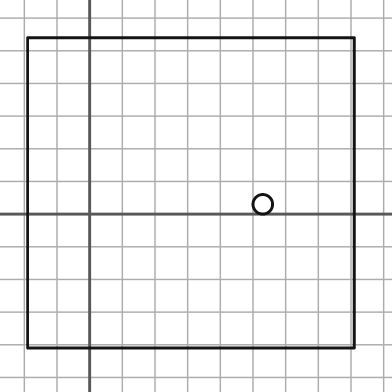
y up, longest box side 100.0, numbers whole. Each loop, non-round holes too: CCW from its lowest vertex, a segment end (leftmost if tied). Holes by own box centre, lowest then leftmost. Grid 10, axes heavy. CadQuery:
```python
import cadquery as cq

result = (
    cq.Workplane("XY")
    .moveTo(-19.0, -41.0)
    .lineTo(81.0, -41.0)
    .lineTo(81.0, 54.0)
    .lineTo(-19.0, 54.0)
    .close()
    .moveTo(53.0, 3.0)
    .circle(3.0)
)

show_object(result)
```